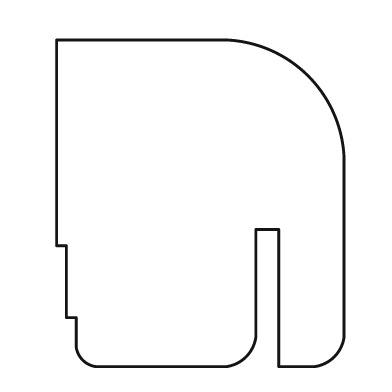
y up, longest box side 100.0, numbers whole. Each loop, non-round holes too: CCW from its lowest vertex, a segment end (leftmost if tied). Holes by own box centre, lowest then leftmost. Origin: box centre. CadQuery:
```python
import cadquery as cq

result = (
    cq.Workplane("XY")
    .moveTo(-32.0, -50.0)
    .lineTo(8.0, -50.0)
    .threePointArc((14.0, -47.0), (17.0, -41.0))
    .lineTo(17.0, -8.0)
    .lineTo(24.0, -8.0)
    .lineTo(24.0, -50.0)
    .lineTo(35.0, -50.0)
    .threePointArc((41.0, -47.0), (44.0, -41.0))
    .lineTo(44.0, 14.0)
    .threePointArc((33.0, 39.0), (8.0, 50.0))
    .lineTo(-44.0, 50.0)
    .lineTo(-44.0, -13.0)
    .lineTo(-41.0, -13.0)
    .lineTo(-41.0, -35.0)
    .lineTo(-38.0, -35.0)
    .lineTo(-38.0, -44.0)
    .threePointArc((-36.0, -48.0), (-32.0, -50.0))
    .close()
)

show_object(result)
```